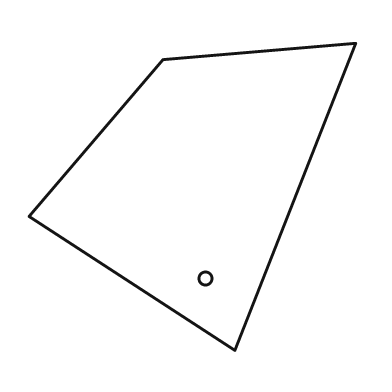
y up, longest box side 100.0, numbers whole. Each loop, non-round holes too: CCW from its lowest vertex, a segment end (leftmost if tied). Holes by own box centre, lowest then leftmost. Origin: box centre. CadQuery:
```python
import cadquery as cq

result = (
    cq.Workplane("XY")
    .moveTo(13.0, -47.0)
    .lineTo(50.0, 47.0)
    .lineTo(-9.0, 42.0)
    .lineTo(-50.0, -6.0)
    .close()
    .moveTo(4.0, -25.0)
    .circle(2.0)
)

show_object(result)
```